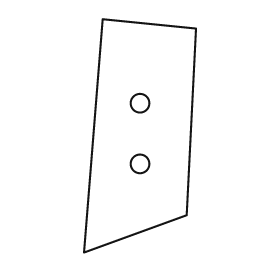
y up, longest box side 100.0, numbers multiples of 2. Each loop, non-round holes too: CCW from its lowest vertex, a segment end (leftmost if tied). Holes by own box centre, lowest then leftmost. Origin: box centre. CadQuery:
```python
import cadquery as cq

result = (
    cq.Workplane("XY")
    .moveTo(-24.0, -50.0)
    .lineTo(20.0, -34.0)
    .lineTo(24.0, 46.0)
    .lineTo(-16.0, 50.0)
    .close()
    .moveTo(0.0, -12.0)
    .circle(4.0)
    .moveTo(0.0, 14.0)
    .circle(4.0)
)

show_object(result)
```